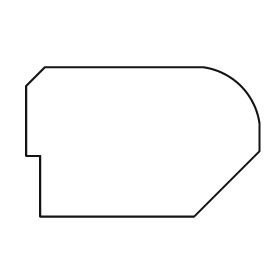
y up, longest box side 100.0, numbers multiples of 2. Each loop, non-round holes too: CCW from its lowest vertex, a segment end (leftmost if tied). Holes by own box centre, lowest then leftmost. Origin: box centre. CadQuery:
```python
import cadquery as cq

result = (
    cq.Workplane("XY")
    .moveTo(-44.0, -32.0)
    .lineTo(22.0, -32.0)
    .lineTo(50.0, -4.0)
    .lineTo(50.0, 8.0)
    .threePointArc((42.0, 24.0), (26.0, 32.0))
    .lineTo(-42.0, 32.0)
    .lineTo(-50.0, 24.0)
    .lineTo(-50.0, -6.0)
    .lineTo(-44.0, -6.0)
    .close()
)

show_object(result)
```